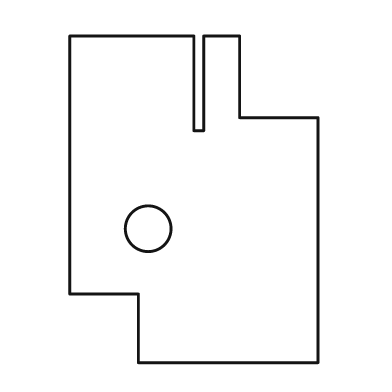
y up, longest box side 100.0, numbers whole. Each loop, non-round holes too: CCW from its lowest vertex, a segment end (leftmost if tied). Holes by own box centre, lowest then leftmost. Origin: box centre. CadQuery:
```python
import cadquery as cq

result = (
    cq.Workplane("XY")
    .moveTo(-17.0, -50.0)
    .lineTo(38.0, -50.0)
    .lineTo(38.0, 25.0)
    .lineTo(14.0, 25.0)
    .lineTo(14.0, 50.0)
    .lineTo(3.0, 50.0)
    .lineTo(3.0, 21.0)
    .lineTo(0.0, 21.0)
    .lineTo(0.0, 50.0)
    .lineTo(-38.0, 50.0)
    .lineTo(-38.0, -29.0)
    .lineTo(-17.0, -29.0)
    .close()
    .moveTo(-14.0, -9.0)
    .circle(7.0)
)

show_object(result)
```